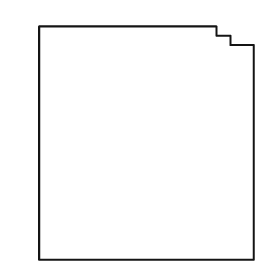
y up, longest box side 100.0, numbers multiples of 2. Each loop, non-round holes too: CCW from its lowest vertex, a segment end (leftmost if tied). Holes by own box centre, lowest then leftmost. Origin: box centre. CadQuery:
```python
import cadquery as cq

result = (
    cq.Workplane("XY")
    .moveTo(-46.0, -50.0)
    .lineTo(46.0, -50.0)
    .lineTo(46.0, 42.0)
    .lineTo(36.0, 42.0)
    .lineTo(36.0, 46.0)
    .lineTo(30.0, 46.0)
    .lineTo(30.0, 50.0)
    .lineTo(-46.0, 50.0)
    .close()
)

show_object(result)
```